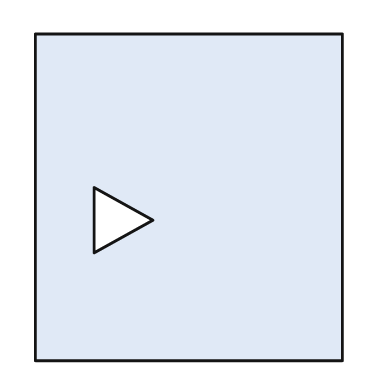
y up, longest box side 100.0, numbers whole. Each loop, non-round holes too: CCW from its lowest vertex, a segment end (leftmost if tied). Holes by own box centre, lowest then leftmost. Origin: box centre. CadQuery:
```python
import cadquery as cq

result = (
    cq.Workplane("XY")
    .moveTo(-47.0, -50.0)
    .lineTo(47.0, -50.0)
    .lineTo(47.0, 50.0)
    .lineTo(-47.0, 50.0)
    .close()
    .moveTo(-29.0, -17.0)
    .lineTo(-11.0, -7.0)
    .lineTo(-29.0, 3.0)
    .close()
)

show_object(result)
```